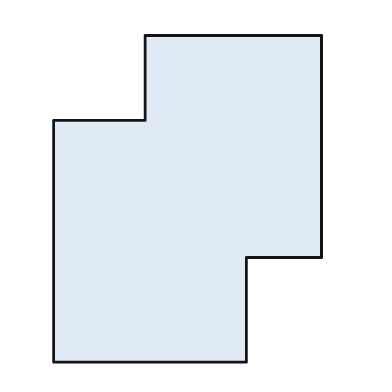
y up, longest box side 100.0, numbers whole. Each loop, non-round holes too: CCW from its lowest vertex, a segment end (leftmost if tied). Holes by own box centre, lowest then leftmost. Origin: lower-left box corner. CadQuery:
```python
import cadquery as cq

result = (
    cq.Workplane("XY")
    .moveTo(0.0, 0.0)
    .lineTo(59.0, 0.0)
    .lineTo(59.0, 32.0)
    .lineTo(82.0, 32.0)
    .lineTo(82.0, 100.0)
    .lineTo(28.0, 100.0)
    .lineTo(28.0, 74.0)
    .lineTo(0.0, 74.0)
    .close()
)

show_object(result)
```